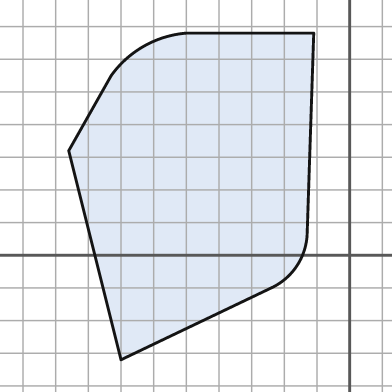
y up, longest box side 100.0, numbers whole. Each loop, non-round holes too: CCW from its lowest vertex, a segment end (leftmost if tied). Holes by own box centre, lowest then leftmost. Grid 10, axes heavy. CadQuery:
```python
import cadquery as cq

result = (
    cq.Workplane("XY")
    .moveTo(-70.0, -32.0)
    .lineTo(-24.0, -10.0)
    .threePointArc((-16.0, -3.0), (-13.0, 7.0))
    .lineTo(-11.0, 68.0)
    .lineTo(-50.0, 68.0)
    .threePointArc((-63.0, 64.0), (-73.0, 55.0))
    .lineTo(-86.0, 32.0)
    .close()
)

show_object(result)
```